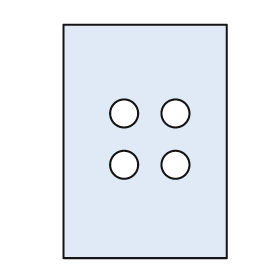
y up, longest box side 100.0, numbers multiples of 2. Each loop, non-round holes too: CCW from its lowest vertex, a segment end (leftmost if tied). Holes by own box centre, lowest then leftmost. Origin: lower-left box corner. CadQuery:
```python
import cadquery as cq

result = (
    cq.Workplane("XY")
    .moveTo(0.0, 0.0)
    .lineTo(70.0, 0.0)
    .lineTo(70.0, 100.0)
    .lineTo(0.0, 100.0)
    .close()
    .moveTo(26.0, 40.0)
    .circle(6.0)
    .moveTo(48.0, 40.0)
    .circle(6.0)
    .moveTo(26.0, 62.0)
    .circle(6.0)
    .moveTo(48.0, 62.0)
    .circle(6.0)
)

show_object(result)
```